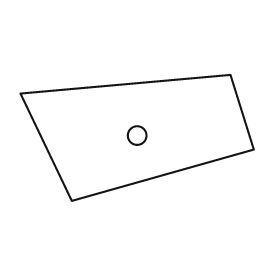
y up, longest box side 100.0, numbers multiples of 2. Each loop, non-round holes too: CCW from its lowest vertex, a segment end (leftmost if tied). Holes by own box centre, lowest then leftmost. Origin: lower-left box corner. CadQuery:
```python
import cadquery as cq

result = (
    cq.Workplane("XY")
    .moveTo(22.0, 0.0)
    .lineTo(100.0, 22.0)
    .lineTo(90.0, 54.0)
    .lineTo(0.0, 46.0)
    .close()
    .moveTo(50.0, 28.0)
    .circle(4.0)
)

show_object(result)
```